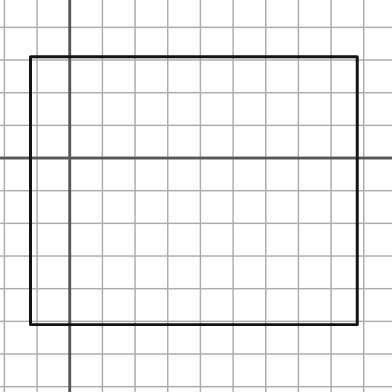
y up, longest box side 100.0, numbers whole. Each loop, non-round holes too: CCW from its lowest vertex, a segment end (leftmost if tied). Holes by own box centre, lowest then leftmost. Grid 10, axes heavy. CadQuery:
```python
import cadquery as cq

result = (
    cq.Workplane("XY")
    .moveTo(-12.0, -51.0)
    .lineTo(88.0, -51.0)
    .lineTo(88.0, 31.0)
    .lineTo(-12.0, 31.0)
    .close()
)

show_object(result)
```